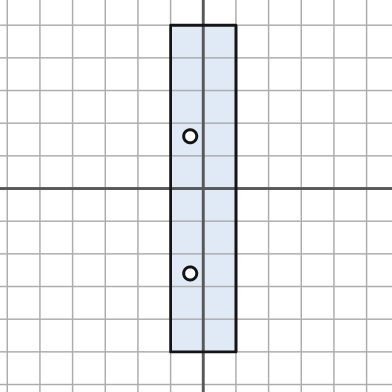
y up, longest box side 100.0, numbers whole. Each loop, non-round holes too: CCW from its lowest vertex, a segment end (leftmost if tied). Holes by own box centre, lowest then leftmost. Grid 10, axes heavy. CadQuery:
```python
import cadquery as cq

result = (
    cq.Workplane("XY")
    .moveTo(-10.0, -50.0)
    .lineTo(10.0, -50.0)
    .lineTo(10.0, 50.0)
    .lineTo(-10.0, 50.0)
    .close()
    .moveTo(-4.0, -26.0)
    .circle(2.0)
    .moveTo(-4.0, 16.0)
    .circle(2.0)
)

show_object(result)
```